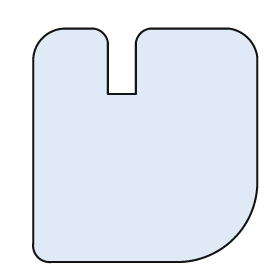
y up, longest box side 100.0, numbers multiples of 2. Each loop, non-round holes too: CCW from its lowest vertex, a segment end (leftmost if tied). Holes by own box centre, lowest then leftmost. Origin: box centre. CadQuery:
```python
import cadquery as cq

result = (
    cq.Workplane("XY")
    .moveTo(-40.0, -50.0)
    .lineTo(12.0, -50.0)
    .threePointArc((38.0, -40.0), (48.0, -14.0))
    .lineTo(48.0, 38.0)
    .threePointArc((44.0, 46.0), (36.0, 50.0))
    .lineTo(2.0, 50.0)
    .threePointArc((-2.0, 48.0), (-4.0, 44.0))
    .lineTo(-4.0, 22.0)
    .lineTo(-16.0, 22.0)
    .lineTo(-16.0, 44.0)
    .threePointArc((-18.0, 48.0), (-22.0, 50.0))
    .lineTo(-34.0, 50.0)
    .threePointArc((-44.0, 46.0), (-48.0, 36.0))
    .lineTo(-48.0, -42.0)
    .threePointArc((-46.0, -48.0), (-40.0, -50.0))
    .close()
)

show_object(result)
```